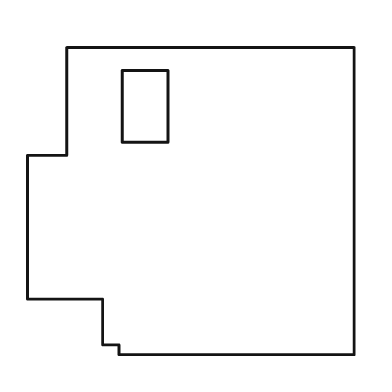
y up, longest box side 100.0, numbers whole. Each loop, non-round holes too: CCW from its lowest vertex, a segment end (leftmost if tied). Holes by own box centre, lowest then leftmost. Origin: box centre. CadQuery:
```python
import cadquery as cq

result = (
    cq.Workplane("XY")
    .moveTo(-22.0, -47.0)
    .lineTo(50.0, -47.0)
    .lineTo(50.0, 47.0)
    .lineTo(-38.0, 47.0)
    .lineTo(-38.0, 14.0)
    .lineTo(-50.0, 14.0)
    .lineTo(-50.0, -30.0)
    .lineTo(-27.0, -30.0)
    .lineTo(-27.0, -44.0)
    .lineTo(-22.0, -44.0)
    .close()
    .moveTo(-21.0, 18.0)
    .lineTo(-7.0, 18.0)
    .lineTo(-7.0, 40.0)
    .lineTo(-21.0, 40.0)
    .close()
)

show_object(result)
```